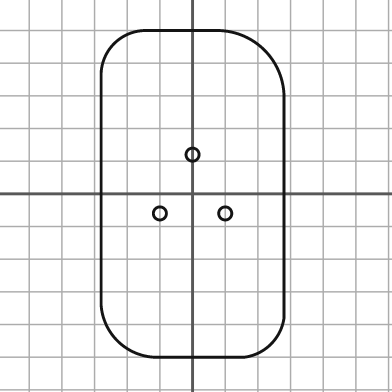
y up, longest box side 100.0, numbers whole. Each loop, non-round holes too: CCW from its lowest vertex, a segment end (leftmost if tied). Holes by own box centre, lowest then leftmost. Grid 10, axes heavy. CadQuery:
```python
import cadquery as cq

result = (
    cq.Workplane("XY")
    .moveTo(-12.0, -50.0)
    .lineTo(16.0, -50.0)
    .threePointArc((24.0, -46.0), (28.0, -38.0))
    .lineTo(28.0, 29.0)
    .threePointArc((22.0, 44.0), (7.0, 50.0))
    .lineTo(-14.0, 50.0)
    .threePointArc((-24.0, 46.0), (-28.0, 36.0))
    .lineTo(-28.0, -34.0)
    .threePointArc((-23.0, -45.0), (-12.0, -50.0))
    .close()
    .moveTo(-10.0, -6.0)
    .circle(2.0)
    .moveTo(10.0, -6.0)
    .circle(2.0)
    .moveTo(0.0, 12.0)
    .circle(2.0)
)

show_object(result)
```